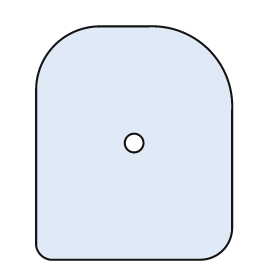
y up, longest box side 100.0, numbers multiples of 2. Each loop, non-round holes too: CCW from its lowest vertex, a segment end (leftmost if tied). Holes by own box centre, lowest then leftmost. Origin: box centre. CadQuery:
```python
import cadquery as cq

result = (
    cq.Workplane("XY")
    .moveTo(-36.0, -50.0)
    .lineTo(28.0, -50.0)
    .threePointArc((38.0, -46.0), (42.0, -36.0))
    .lineTo(42.0, 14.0)
    .threePointArc((32.0, 40.0), (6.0, 50.0))
    .lineTo(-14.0, 50.0)
    .threePointArc((-34.0, 42.0), (-42.0, 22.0))
    .lineTo(-42.0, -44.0)
    .threePointArc((-40.0, -48.0), (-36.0, -50.0))
    .close()
    .moveTo(0.0, 0.0)
    .circle(4.0)
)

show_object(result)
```